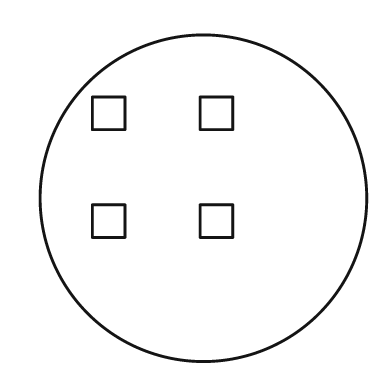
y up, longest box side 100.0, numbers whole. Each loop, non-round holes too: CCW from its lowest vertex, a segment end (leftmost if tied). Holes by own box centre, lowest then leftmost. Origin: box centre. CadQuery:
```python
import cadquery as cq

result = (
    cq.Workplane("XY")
    .moveTo(0.0, 0.0)
    .circle(50.0)
    .moveTo(-34.0, -12.0)
    .lineTo(-24.0, -12.0)
    .lineTo(-24.0, -2.0)
    .lineTo(-34.0, -2.0)
    .close()
    .moveTo(-1.0, -12.0)
    .lineTo(9.0, -12.0)
    .lineTo(9.0, -2.0)
    .lineTo(-1.0, -2.0)
    .close()
    .moveTo(-34.0, 21.0)
    .lineTo(-24.0, 21.0)
    .lineTo(-24.0, 31.0)
    .lineTo(-34.0, 31.0)
    .close()
    .moveTo(-1.0, 21.0)
    .lineTo(9.0, 21.0)
    .lineTo(9.0, 31.0)
    .lineTo(-1.0, 31.0)
    .close()
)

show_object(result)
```